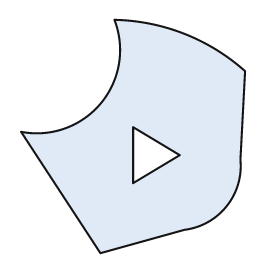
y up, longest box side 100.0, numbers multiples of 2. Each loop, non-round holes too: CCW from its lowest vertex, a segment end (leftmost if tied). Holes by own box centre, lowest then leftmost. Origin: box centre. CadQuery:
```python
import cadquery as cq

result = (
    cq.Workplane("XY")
    .moveTo(-14.0, -50.0)
    .lineTo(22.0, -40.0)
    .threePointArc((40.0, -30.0), (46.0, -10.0))
    .lineTo(48.0, 28.0)
    .threePointArc((22.0, 44.0), (-8.0, 50.0))
    .threePointArc((-14.0, 14.0), (-48.0, 2.0))
    .close()
    .moveTo(0.0, -20.0)
    .lineTo(20.0, -8.0)
    .lineTo(0.0, 4.0)
    .close()
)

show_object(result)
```